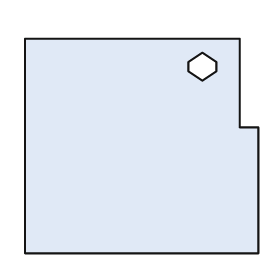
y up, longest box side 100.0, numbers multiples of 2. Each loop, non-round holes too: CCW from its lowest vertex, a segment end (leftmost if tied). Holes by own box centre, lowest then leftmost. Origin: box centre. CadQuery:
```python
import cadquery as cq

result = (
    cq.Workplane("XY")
    .moveTo(-50.0, -46.0)
    .lineTo(50.0, -46.0)
    .lineTo(50.0, 8.0)
    .lineTo(42.0, 8.0)
    .lineTo(42.0, 46.0)
    .lineTo(-50.0, 46.0)
    .close()
    .moveTo(26.0, 28.0)
    .lineTo(32.0, 32.0)
    .lineTo(32.0, 36.0)
    .lineTo(26.0, 40.0)
    .lineTo(20.0, 36.0)
    .lineTo(20.0, 32.0)
    .close()
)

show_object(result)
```